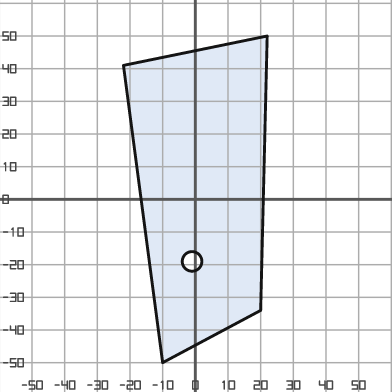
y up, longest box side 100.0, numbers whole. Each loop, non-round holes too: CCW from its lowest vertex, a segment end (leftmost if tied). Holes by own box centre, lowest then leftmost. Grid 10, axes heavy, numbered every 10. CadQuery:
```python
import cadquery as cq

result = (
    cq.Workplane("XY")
    .moveTo(-10.0, -50.0)
    .lineTo(20.0, -34.0)
    .lineTo(22.0, 50.0)
    .lineTo(-22.0, 41.0)
    .close()
    .moveTo(-1.0, -19.0)
    .circle(3.0)
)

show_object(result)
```